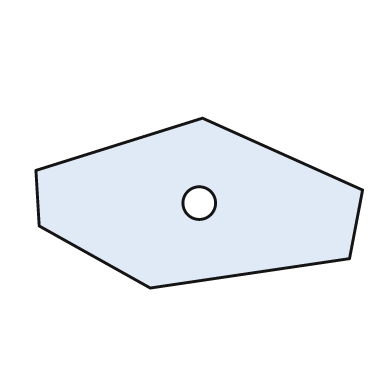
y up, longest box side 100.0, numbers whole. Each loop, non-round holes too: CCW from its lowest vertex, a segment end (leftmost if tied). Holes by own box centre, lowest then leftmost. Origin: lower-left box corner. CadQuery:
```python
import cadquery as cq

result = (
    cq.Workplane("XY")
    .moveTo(35.0, 0.0)
    .lineTo(96.0, 9.0)
    .lineTo(100.0, 30.0)
    .lineTo(51.0, 52.0)
    .lineTo(0.0, 36.0)
    .lineTo(1.0, 19.0)
    .close()
    .moveTo(50.0, 26.0)
    .circle(5.0)
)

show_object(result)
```